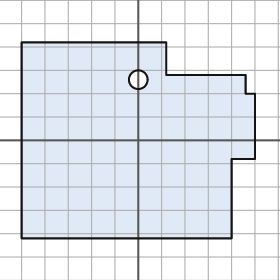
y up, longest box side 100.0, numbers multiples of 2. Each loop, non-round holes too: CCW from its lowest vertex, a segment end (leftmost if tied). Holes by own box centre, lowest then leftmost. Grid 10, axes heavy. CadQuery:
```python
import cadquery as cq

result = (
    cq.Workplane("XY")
    .moveTo(-50.0, -42.0)
    .lineTo(40.0, -42.0)
    .lineTo(40.0, -8.0)
    .lineTo(50.0, -8.0)
    .lineTo(50.0, 20.0)
    .lineTo(46.0, 20.0)
    .lineTo(46.0, 28.0)
    .lineTo(12.0, 28.0)
    .lineTo(12.0, 42.0)
    .lineTo(-50.0, 42.0)
    .close()
    .moveTo(0.0, 26.0)
    .circle(4.0)
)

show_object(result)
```